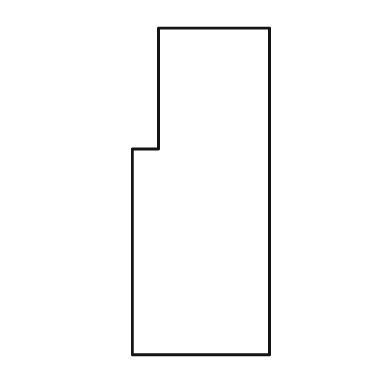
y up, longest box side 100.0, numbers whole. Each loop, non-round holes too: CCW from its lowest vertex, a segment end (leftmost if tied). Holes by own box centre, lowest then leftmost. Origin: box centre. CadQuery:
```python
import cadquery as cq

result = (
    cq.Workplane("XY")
    .moveTo(-21.0, -50.0)
    .lineTo(21.0, -50.0)
    .lineTo(21.0, 50.0)
    .lineTo(-13.0, 50.0)
    .lineTo(-13.0, 13.0)
    .lineTo(-21.0, 13.0)
    .close()
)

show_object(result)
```